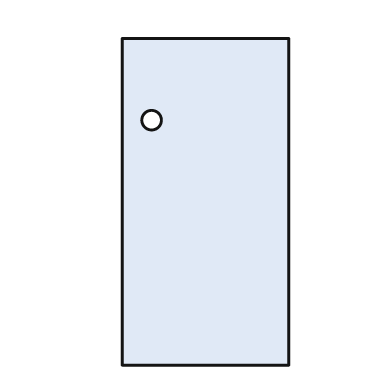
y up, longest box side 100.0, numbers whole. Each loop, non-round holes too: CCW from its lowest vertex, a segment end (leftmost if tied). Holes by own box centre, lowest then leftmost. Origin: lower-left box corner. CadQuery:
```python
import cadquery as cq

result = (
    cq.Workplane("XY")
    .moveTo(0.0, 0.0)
    .lineTo(51.0, 0.0)
    .lineTo(51.0, 100.0)
    .lineTo(0.0, 100.0)
    .close()
    .moveTo(9.0, 75.0)
    .circle(3.0)
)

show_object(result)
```